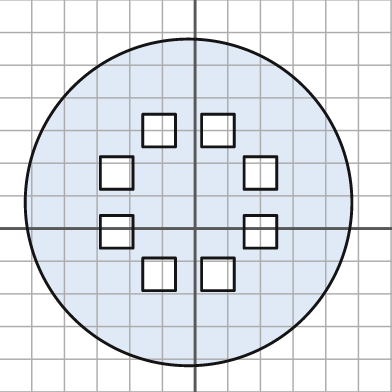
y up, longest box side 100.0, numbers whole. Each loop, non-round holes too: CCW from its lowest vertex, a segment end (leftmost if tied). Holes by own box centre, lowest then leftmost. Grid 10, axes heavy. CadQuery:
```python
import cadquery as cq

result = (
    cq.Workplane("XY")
    .moveTo(-2.0, 8.0)
    .circle(50.0)
    .moveTo(-16.0, -19.0)
    .lineTo(-6.0, -19.0)
    .lineTo(-6.0, -9.0)
    .lineTo(-16.0, -9.0)
    .close()
    .moveTo(2.0, -19.0)
    .lineTo(12.0, -19.0)
    .lineTo(12.0, -9.0)
    .lineTo(2.0, -9.0)
    .close()
    .moveTo(-29.0, -6.0)
    .lineTo(-19.0, -6.0)
    .lineTo(-19.0, 4.0)
    .lineTo(-29.0, 4.0)
    .close()
    .moveTo(15.0, -6.0)
    .lineTo(25.0, -6.0)
    .lineTo(25.0, 4.0)
    .lineTo(15.0, 4.0)
    .close()
    .moveTo(-29.0, 12.0)
    .lineTo(-19.0, 12.0)
    .lineTo(-19.0, 22.0)
    .lineTo(-29.0, 22.0)
    .close()
    .moveTo(15.0, 12.0)
    .lineTo(25.0, 12.0)
    .lineTo(25.0, 22.0)
    .lineTo(15.0, 22.0)
    .close()
    .moveTo(-16.0, 25.0)
    .lineTo(-6.0, 25.0)
    .lineTo(-6.0, 35.0)
    .lineTo(-16.0, 35.0)
    .close()
    .moveTo(2.0, 25.0)
    .lineTo(12.0, 25.0)
    .lineTo(12.0, 35.0)
    .lineTo(2.0, 35.0)
    .close()
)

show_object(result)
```